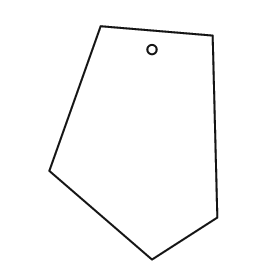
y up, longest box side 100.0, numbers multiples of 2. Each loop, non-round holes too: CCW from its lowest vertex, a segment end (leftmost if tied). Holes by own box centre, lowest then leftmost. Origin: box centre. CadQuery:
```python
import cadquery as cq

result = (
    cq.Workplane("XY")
    .moveTo(8.0, -50.0)
    .lineTo(36.0, -32.0)
    .lineTo(34.0, 46.0)
    .lineTo(-14.0, 50.0)
    .lineTo(-36.0, -12.0)
    .close()
    .moveTo(8.0, 40.0)
    .circle(2.0)
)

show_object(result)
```